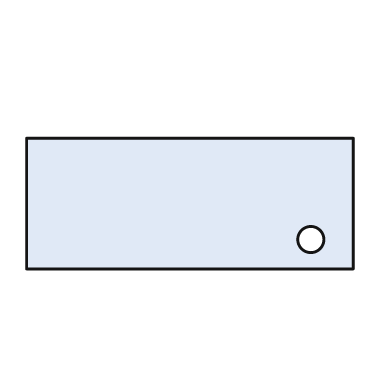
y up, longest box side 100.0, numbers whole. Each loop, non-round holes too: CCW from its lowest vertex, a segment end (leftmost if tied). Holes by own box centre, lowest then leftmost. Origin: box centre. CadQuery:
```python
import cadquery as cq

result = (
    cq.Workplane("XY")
    .moveTo(-50.0, -20.0)
    .lineTo(50.0, -20.0)
    .lineTo(50.0, 20.0)
    .lineTo(-50.0, 20.0)
    .close()
    .moveTo(37.0, -11.0)
    .circle(4.0)
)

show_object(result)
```